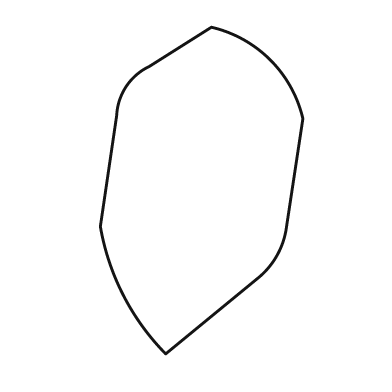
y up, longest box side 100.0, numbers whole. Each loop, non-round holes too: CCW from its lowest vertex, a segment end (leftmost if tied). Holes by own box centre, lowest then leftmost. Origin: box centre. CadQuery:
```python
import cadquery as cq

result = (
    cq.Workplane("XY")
    .moveTo(-11.0, -50.0)
    .lineTo(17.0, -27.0)
    .threePointArc((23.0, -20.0), (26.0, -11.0))
    .lineTo(31.0, 22.0)
    .threePointArc((21.0, 40.0), (3.0, 50.0))
    .lineTo(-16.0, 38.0)
    .threePointArc((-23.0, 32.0), (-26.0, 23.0))
    .lineTo(-31.0, -11.0)
    .threePointArc((-24.0, -32.0), (-11.0, -50.0))
    .close()
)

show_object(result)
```